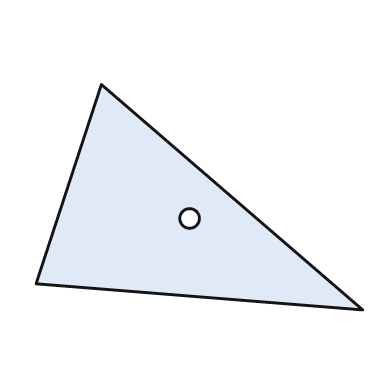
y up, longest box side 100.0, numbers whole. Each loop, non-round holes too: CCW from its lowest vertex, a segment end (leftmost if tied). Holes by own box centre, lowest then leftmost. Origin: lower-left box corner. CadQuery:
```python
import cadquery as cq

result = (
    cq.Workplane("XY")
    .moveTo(100.0, 0.0)
    .lineTo(20.0, 69.0)
    .lineTo(0.0, 8.0)
    .close()
    .moveTo(47.0, 28.0)
    .circle(3.0)
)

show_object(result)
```